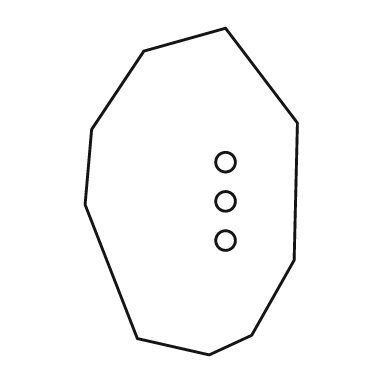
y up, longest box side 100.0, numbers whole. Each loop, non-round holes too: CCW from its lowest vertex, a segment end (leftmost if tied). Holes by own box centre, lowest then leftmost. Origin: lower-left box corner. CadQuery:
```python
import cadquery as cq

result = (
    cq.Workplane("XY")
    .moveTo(38.0, 0.0)
    .lineTo(51.0, 6.0)
    .lineTo(64.0, 29.0)
    .lineTo(65.0, 71.0)
    .lineTo(43.0, 100.0)
    .lineTo(18.0, 93.0)
    .lineTo(2.0, 69.0)
    .lineTo(0.0, 46.0)
    .lineTo(16.0, 5.0)
    .close()
    .moveTo(43.0, 35.0)
    .circle(3.0)
    .moveTo(43.0, 47.0)
    .circle(3.0)
    .moveTo(43.0, 59.0)
    .circle(3.0)
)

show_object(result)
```